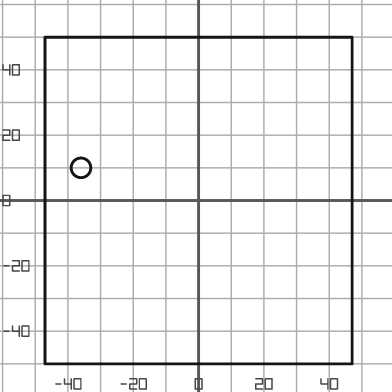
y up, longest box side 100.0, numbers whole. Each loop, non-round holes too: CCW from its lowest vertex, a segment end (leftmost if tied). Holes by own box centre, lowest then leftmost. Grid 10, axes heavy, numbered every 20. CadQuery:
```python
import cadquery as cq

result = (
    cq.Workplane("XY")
    .moveTo(-47.0, -50.0)
    .lineTo(47.0, -50.0)
    .lineTo(47.0, 50.0)
    .lineTo(-47.0, 50.0)
    .close()
    .moveTo(-36.0, 10.0)
    .circle(3.0)
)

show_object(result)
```